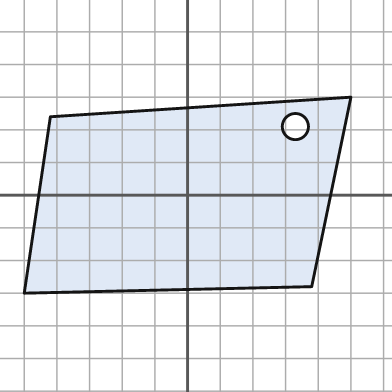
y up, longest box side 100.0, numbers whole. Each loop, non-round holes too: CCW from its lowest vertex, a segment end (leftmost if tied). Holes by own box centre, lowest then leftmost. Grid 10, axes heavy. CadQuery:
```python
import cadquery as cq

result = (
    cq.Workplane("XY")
    .moveTo(-50.0, -30.0)
    .lineTo(38.0, -28.0)
    .lineTo(50.0, 30.0)
    .lineTo(-42.0, 24.0)
    .close()
    .moveTo(33.0, 21.0)
    .circle(4.0)
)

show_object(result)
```